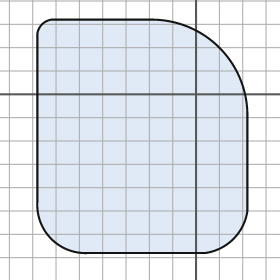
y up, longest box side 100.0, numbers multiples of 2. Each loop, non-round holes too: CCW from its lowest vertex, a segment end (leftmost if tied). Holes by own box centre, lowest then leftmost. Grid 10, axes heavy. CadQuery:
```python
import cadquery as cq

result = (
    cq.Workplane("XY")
    .moveTo(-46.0, -68.0)
    .lineTo(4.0, -68.0)
    .threePointArc((16.0, -62.0), (22.0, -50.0))
    .lineTo(22.0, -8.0)
    .threePointArc((10.0, 20.0), (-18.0, 32.0))
    .lineTo(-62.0, 32.0)
    .threePointArc((-66.0, 30.0), (-68.0, 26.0))
    .lineTo(-68.0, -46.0)
    .threePointArc((-62.0, -62.0), (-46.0, -68.0))
    .close()
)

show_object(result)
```